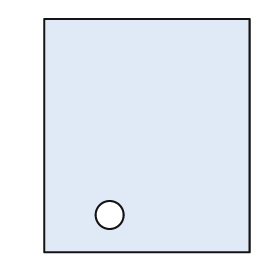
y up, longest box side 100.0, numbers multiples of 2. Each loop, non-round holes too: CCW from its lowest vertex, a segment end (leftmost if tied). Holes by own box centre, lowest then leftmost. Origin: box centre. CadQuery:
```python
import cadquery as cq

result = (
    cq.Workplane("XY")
    .moveTo(-44.0, -50.0)
    .lineTo(44.0, -50.0)
    .lineTo(44.0, 50.0)
    .lineTo(-44.0, 50.0)
    .close()
    .moveTo(-16.0, -34.0)
    .circle(6.0)
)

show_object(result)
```